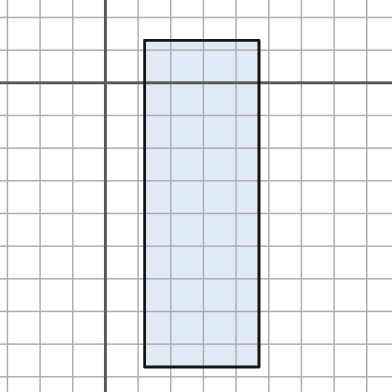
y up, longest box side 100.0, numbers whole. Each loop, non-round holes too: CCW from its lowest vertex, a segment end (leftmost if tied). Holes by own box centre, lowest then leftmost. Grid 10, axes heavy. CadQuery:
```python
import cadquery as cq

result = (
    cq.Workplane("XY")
    .moveTo(12.0, -87.0)
    .lineTo(47.0, -87.0)
    .lineTo(47.0, 13.0)
    .lineTo(12.0, 13.0)
    .close()
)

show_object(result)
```